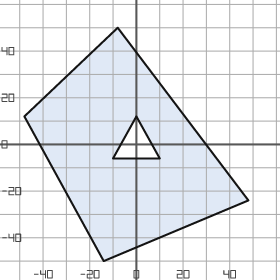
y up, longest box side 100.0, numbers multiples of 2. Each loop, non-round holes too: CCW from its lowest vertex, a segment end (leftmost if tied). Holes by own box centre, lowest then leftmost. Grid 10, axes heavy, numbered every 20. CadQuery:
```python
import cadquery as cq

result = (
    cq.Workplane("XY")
    .moveTo(-14.0, -50.0)
    .lineTo(48.0, -24.0)
    .lineTo(-8.0, 50.0)
    .lineTo(-48.0, 12.0)
    .close()
    .moveTo(-10.0, -6.0)
    .lineTo(10.0, -6.0)
    .lineTo(0.0, 12.0)
    .close()
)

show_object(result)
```